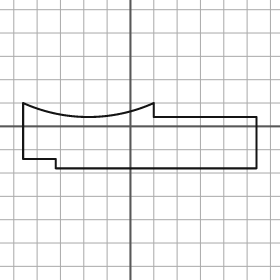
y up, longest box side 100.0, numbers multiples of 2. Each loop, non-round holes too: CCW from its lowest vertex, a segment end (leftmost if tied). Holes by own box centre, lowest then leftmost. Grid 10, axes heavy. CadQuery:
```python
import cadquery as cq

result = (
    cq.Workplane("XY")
    .moveTo(-32.0, -18.0)
    .lineTo(54.0, -18.0)
    .lineTo(54.0, 4.0)
    .lineTo(10.0, 4.0)
    .lineTo(10.0, 10.0)
    .threePointArc((-18.0, 4.0), (-46.0, 10.0))
    .lineTo(-46.0, -14.0)
    .lineTo(-32.0, -14.0)
    .close()
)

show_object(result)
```